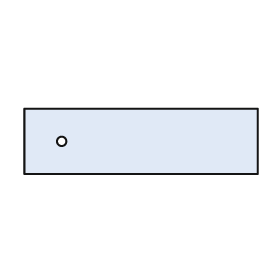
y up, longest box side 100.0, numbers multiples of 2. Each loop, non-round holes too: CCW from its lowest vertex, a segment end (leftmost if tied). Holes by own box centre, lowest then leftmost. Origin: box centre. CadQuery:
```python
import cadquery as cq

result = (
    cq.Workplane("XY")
    .moveTo(-50.0, -14.0)
    .lineTo(50.0, -14.0)
    .lineTo(50.0, 14.0)
    .lineTo(-50.0, 14.0)
    .close()
    .moveTo(-34.0, 0.0)
    .circle(2.0)
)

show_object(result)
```